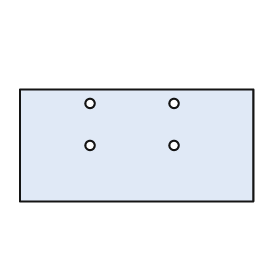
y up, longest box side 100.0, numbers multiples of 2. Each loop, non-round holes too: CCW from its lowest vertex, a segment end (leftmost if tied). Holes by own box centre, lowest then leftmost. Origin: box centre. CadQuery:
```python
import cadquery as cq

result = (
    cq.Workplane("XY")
    .moveTo(-50.0, -24.0)
    .lineTo(50.0, -24.0)
    .lineTo(50.0, 24.0)
    .lineTo(-50.0, 24.0)
    .close()
    .moveTo(-20.0, 0.0)
    .circle(2.0)
    .moveTo(16.0, 0.0)
    .circle(2.0)
    .moveTo(-20.0, 18.0)
    .circle(2.0)
    .moveTo(16.0, 18.0)
    .circle(2.0)
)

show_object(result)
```